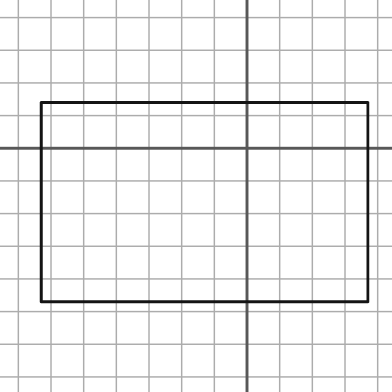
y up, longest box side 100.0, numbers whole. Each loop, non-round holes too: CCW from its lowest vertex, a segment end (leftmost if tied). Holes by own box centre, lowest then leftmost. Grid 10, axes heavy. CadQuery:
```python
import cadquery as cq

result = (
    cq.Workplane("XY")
    .moveTo(-63.0, -47.0)
    .lineTo(37.0, -47.0)
    .lineTo(37.0, 14.0)
    .lineTo(-63.0, 14.0)
    .close()
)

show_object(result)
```